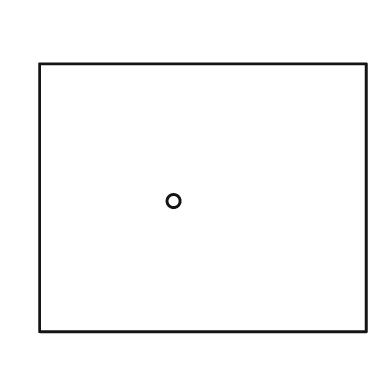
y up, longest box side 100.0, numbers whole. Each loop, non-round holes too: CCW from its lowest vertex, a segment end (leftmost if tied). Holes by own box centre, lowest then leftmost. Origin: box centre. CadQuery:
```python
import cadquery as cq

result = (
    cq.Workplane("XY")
    .moveTo(-50.0, -41.0)
    .lineTo(50.0, -41.0)
    .lineTo(50.0, 41.0)
    .lineTo(-50.0, 41.0)
    .close()
    .moveTo(-9.0, -1.0)
    .circle(2.0)
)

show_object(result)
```